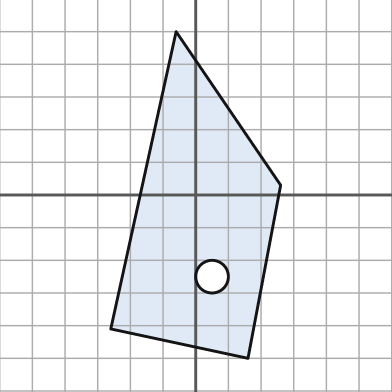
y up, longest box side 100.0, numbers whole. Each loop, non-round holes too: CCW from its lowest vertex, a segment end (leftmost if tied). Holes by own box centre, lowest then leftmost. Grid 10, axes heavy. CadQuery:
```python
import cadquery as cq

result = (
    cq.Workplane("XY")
    .moveTo(16.0, -50.0)
    .lineTo(26.0, 3.0)
    .lineTo(-6.0, 50.0)
    .lineTo(-26.0, -41.0)
    .close()
    .moveTo(5.0, -25.0)
    .circle(5.0)
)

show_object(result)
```